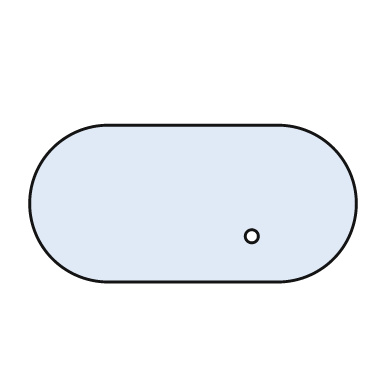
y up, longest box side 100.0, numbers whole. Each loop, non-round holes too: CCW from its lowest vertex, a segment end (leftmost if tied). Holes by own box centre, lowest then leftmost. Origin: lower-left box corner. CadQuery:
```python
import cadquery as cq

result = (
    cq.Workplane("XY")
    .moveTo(24.0, 0.0)
    .lineTo(76.0, 0.0)
    .threePointArc((100.0, 24.0), (76.0, 48.0))
    .lineTo(24.0, 48.0)
    .threePointArc((0.0, 24.0), (24.0, 0.0))
    .close()
    .moveTo(68.0, 14.0)
    .circle(2.0)
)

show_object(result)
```